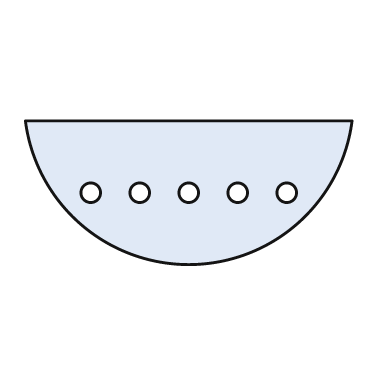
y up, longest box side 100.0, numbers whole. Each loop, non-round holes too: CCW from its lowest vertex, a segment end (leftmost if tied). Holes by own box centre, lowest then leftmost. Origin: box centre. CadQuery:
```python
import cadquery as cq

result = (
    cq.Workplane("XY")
    .moveTo(-50.0, 22.0)
    .threePointArc((0.0, -22.0), (50.0, 22.0))
    .close()
    .moveTo(-30.0, 0.0)
    .circle(3.0)
    .moveTo(-15.0, 0.0)
    .circle(3.0)
    .moveTo(0.0, 0.0)
    .circle(3.0)
    .moveTo(15.0, 0.0)
    .circle(3.0)
    .moveTo(30.0, 0.0)
    .circle(3.0)
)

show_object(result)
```